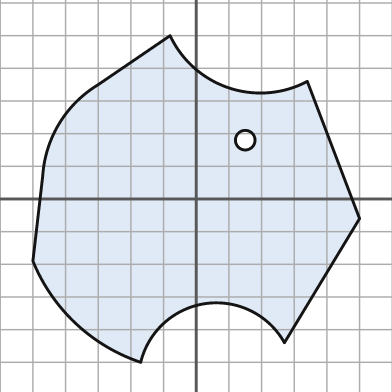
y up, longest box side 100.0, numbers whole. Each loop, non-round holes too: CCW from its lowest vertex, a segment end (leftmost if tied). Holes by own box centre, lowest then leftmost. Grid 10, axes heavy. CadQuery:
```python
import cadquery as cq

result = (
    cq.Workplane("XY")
    .moveTo(-17.0, -50.0)
    .threePointArc((3.0, -32.0), (27.0, -44.0))
    .lineTo(50.0, -6.0)
    .lineTo(34.0, 36.0)
    .threePointArc((10.0, 34.0), (-8.0, 50.0))
    .lineTo(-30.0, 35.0)
    .threePointArc((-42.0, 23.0), (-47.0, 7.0))
    .lineTo(-50.0, -19.0)
    .threePointArc((-37.0, -38.0), (-17.0, -50.0))
    .close()
    .moveTo(15.0, 18.0)
    .circle(3.0)
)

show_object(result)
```